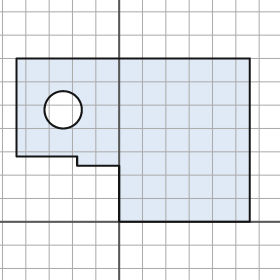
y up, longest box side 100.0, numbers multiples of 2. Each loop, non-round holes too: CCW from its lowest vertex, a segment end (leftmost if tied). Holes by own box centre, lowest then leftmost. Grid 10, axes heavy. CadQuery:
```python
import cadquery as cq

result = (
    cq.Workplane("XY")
    .moveTo(0.0, 0.0)
    .lineTo(56.0, 0.0)
    .lineTo(56.0, 70.0)
    .lineTo(-44.0, 70.0)
    .lineTo(-44.0, 28.0)
    .lineTo(-18.0, 28.0)
    .lineTo(-18.0, 24.0)
    .lineTo(0.0, 24.0)
    .close()
    .moveTo(-24.0, 48.0)
    .circle(8.0)
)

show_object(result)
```